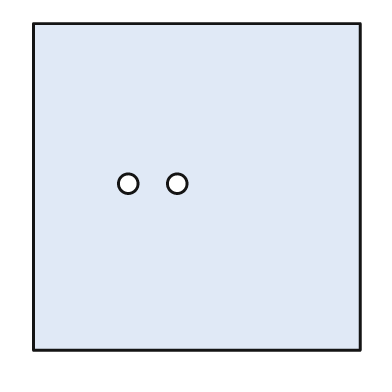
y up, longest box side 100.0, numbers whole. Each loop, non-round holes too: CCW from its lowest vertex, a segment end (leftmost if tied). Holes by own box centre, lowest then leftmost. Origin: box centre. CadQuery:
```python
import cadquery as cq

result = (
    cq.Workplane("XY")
    .moveTo(-50.0, -50.0)
    .lineTo(50.0, -50.0)
    .lineTo(50.0, 50.0)
    .lineTo(-50.0, 50.0)
    .close()
    .moveTo(-21.0, 1.0)
    .circle(3.0)
    .moveTo(-6.0, 1.0)
    .circle(3.0)
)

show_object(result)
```